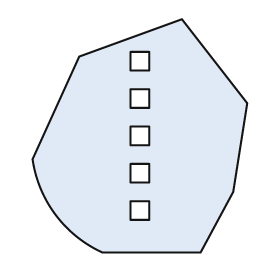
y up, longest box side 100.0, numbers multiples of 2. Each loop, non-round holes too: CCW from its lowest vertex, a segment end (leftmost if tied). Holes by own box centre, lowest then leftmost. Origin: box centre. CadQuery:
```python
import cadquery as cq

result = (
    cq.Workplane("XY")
    .moveTo(-16.0, -50.0)
    .lineTo(26.0, -50.0)
    .lineTo(40.0, -24.0)
    .lineTo(46.0, 14.0)
    .lineTo(18.0, 50.0)
    .lineTo(-26.0, 34.0)
    .lineTo(-46.0, -10.0)
    .threePointArc((-36.0, -34.0), (-16.0, -50.0))
    .close()
    .moveTo(-4.0, -36.0)
    .lineTo(4.0, -36.0)
    .lineTo(4.0, -28.0)
    .lineTo(-4.0, -28.0)
    .close()
    .moveTo(-4.0, -20.0)
    .lineTo(4.0, -20.0)
    .lineTo(4.0, -12.0)
    .lineTo(-4.0, -12.0)
    .close()
    .moveTo(-4.0, -4.0)
    .lineTo(4.0, -4.0)
    .lineTo(4.0, 4.0)
    .lineTo(-4.0, 4.0)
    .close()
    .moveTo(-4.0, 12.0)
    .lineTo(4.0, 12.0)
    .lineTo(4.0, 20.0)
    .lineTo(-4.0, 20.0)
    .close()
    .moveTo(-4.0, 28.0)
    .lineTo(4.0, 28.0)
    .lineTo(4.0, 36.0)
    .lineTo(-4.0, 36.0)
    .close()
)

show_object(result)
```